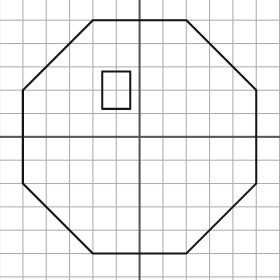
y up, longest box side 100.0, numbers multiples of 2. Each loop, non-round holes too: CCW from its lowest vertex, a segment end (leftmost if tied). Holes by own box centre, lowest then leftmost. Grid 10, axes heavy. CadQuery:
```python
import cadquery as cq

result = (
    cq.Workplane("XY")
    .moveTo(-20.0, -50.0)
    .lineTo(20.0, -50.0)
    .lineTo(50.0, -20.0)
    .lineTo(50.0, 20.0)
    .lineTo(20.0, 50.0)
    .lineTo(-20.0, 50.0)
    .lineTo(-50.0, 20.0)
    .lineTo(-50.0, -20.0)
    .close()
    .moveTo(-16.0, 12.0)
    .lineTo(-4.0, 12.0)
    .lineTo(-4.0, 28.0)
    .lineTo(-16.0, 28.0)
    .close()
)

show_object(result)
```